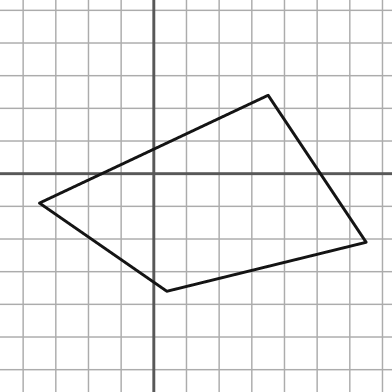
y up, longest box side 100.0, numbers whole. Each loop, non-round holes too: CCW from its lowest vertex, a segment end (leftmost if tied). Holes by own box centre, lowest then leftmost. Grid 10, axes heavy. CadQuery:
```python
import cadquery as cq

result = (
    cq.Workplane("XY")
    .moveTo(4.0, -36.0)
    .lineTo(65.0, -21.0)
    .lineTo(35.0, 24.0)
    .lineTo(-35.0, -9.0)
    .close()
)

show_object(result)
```